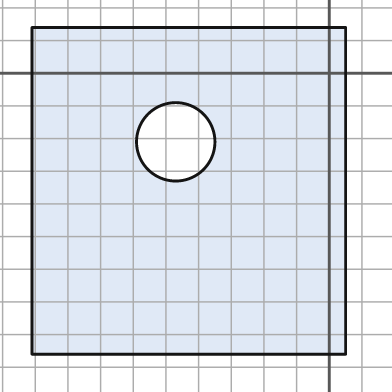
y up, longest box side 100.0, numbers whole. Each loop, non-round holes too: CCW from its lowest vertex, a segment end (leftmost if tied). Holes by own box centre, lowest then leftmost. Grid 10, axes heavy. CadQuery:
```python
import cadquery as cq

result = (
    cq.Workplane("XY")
    .moveTo(-91.0, -86.0)
    .lineTo(5.0, -86.0)
    .lineTo(5.0, 14.0)
    .lineTo(-91.0, 14.0)
    .close()
    .moveTo(-47.0, -21.0)
    .circle(12.0)
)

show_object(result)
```